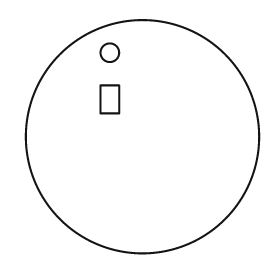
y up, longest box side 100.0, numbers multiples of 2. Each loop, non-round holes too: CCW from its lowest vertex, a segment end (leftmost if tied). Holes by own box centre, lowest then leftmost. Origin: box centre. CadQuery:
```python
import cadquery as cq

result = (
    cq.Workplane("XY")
    .moveTo(0.0, 0.0)
    .circle(50.0)
    .moveTo(-18.0, 10.0)
    .lineTo(-10.0, 10.0)
    .lineTo(-10.0, 22.0)
    .lineTo(-18.0, 22.0)
    .close()
    .moveTo(-14.0, 36.0)
    .circle(4.0)
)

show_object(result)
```